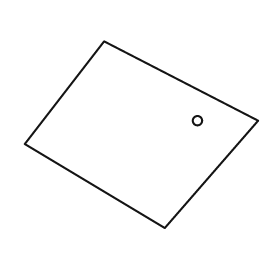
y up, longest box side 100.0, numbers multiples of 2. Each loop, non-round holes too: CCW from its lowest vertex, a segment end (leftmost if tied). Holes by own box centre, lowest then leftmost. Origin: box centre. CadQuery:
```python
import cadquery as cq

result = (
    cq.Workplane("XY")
    .moveTo(10.0, -40.0)
    .lineTo(50.0, 6.0)
    .lineTo(-16.0, 40.0)
    .lineTo(-50.0, -4.0)
    .close()
    .moveTo(24.0, 6.0)
    .circle(2.0)
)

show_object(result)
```